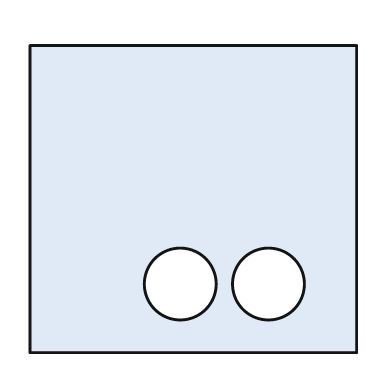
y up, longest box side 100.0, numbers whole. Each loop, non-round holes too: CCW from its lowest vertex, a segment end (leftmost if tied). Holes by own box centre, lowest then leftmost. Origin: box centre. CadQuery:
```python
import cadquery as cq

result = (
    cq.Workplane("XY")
    .moveTo(-50.0, -47.0)
    .lineTo(50.0, -47.0)
    .lineTo(50.0, 47.0)
    .lineTo(-50.0, 47.0)
    .close()
    .moveTo(-4.0, -26.0)
    .circle(11.0)
    .moveTo(23.0, -26.0)
    .circle(11.0)
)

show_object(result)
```